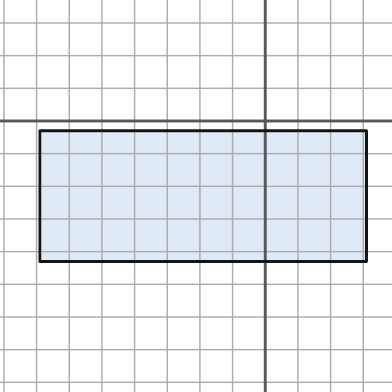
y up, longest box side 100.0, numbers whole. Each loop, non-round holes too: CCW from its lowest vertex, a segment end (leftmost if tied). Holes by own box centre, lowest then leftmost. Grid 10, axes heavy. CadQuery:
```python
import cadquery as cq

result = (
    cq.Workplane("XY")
    .moveTo(-69.0, -43.0)
    .lineTo(31.0, -43.0)
    .lineTo(31.0, -3.0)
    .lineTo(-69.0, -3.0)
    .close()
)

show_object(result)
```